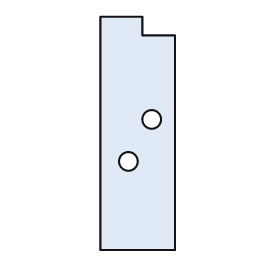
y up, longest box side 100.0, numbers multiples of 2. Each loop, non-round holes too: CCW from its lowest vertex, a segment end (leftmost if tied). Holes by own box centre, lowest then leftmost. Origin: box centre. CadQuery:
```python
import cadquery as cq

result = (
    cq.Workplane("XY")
    .moveTo(-16.0, -50.0)
    .lineTo(16.0, -50.0)
    .lineTo(16.0, 42.0)
    .lineTo(2.0, 42.0)
    .lineTo(2.0, 50.0)
    .lineTo(-16.0, 50.0)
    .close()
    .moveTo(-4.0, -12.0)
    .circle(4.0)
    .moveTo(6.0, 6.0)
    .circle(4.0)
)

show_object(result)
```